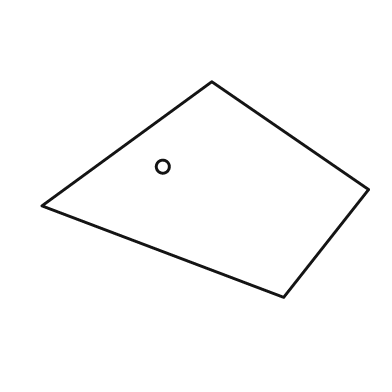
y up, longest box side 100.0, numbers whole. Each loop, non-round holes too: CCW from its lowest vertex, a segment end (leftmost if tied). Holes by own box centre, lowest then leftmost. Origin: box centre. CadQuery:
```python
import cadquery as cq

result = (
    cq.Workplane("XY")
    .moveTo(24.0, -33.0)
    .lineTo(50.0, 0.0)
    .lineTo(2.0, 33.0)
    .lineTo(-50.0, -5.0)
    .close()
    .moveTo(-13.0, 7.0)
    .circle(2.0)
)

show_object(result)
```